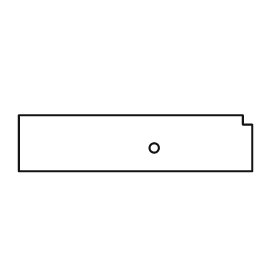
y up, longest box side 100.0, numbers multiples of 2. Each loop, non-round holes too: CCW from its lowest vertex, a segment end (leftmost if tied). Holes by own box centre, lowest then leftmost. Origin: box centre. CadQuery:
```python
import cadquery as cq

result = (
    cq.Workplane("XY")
    .moveTo(-50.0, -12.0)
    .lineTo(50.0, -12.0)
    .lineTo(50.0, 8.0)
    .lineTo(46.0, 8.0)
    .lineTo(46.0, 12.0)
    .lineTo(-50.0, 12.0)
    .close()
    .moveTo(8.0, -2.0)
    .circle(2.0)
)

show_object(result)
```